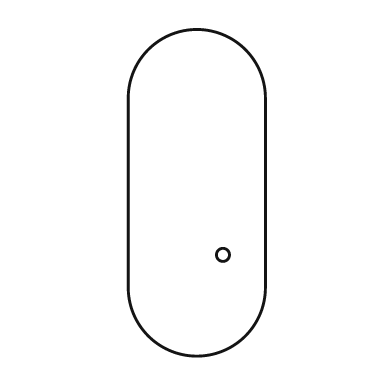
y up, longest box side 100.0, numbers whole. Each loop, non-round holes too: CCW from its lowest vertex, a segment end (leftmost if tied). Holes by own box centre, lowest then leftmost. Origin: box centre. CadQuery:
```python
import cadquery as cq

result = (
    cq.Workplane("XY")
    .moveTo(-21.0, -29.0)
    .threePointArc((0.0, -50.0), (21.0, -29.0))
    .lineTo(21.0, 29.0)
    .threePointArc((0.0, 50.0), (-21.0, 29.0))
    .close()
    .moveTo(8.0, -19.0)
    .circle(2.0)
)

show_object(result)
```